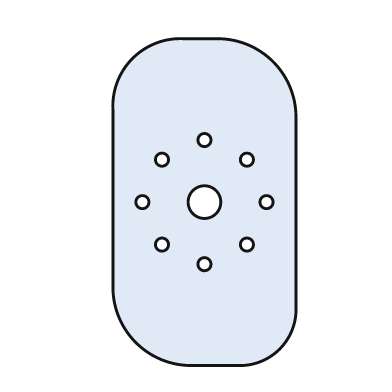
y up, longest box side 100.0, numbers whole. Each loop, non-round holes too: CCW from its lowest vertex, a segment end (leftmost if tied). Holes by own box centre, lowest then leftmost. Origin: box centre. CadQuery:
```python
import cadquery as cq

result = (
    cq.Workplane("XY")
    .moveTo(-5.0, -50.0)
    .lineTo(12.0, -50.0)
    .threePointArc((23.0, -45.0), (28.0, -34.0))
    .lineTo(28.0, 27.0)
    .threePointArc((21.0, 43.0), (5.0, 50.0))
    .lineTo(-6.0, 50.0)
    .threePointArc((-22.0, 44.0), (-28.0, 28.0))
    .lineTo(-28.0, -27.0)
    .threePointArc((-21.0, -43.0), (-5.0, -50.0))
    .close()
    .moveTo(0.0, -19.0)
    .circle(2.0)
    .moveTo(-13.0, -13.0)
    .circle(2.0)
    .moveTo(13.0, -13.0)
    .circle(2.0)
    .moveTo(-19.0, 0.0)
    .circle(2.0)
    .moveTo(0.0, 0.0)
    .circle(5.0)
    .moveTo(19.0, 0.0)
    .circle(2.0)
    .moveTo(-13.0, 13.0)
    .circle(2.0)
    .moveTo(13.0, 13.0)
    .circle(2.0)
    .moveTo(0.0, 19.0)
    .circle(2.0)
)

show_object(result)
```